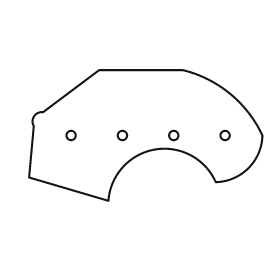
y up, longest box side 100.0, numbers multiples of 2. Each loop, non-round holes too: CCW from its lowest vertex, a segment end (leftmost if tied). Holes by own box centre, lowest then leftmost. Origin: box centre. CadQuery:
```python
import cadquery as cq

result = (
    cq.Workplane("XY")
    .moveTo(-16.0, -28.0)
    .threePointArc((4.0, -6.0), (30.0, -20.0))
    .threePointArc((44.0, -14.0), (50.0, 0.0))
    .threePointArc((36.0, 18.0), (16.0, 28.0))
    .lineTo(-20.0, 28.0)
    .lineTo(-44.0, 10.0)
    .threePointArc((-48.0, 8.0), (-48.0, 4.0))
    .lineTo(-50.0, -18.0)
    .close()
    .moveTo(-32.0, 0.0)
    .circle(2.0)
    .moveTo(-10.0, 0.0)
    .circle(2.0)
    .moveTo(12.0, 0.0)
    .circle(2.0)
    .moveTo(34.0, 0.0)
    .circle(2.0)
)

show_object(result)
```